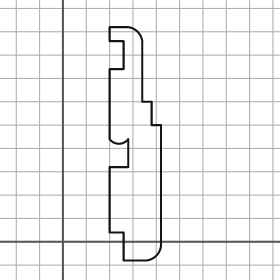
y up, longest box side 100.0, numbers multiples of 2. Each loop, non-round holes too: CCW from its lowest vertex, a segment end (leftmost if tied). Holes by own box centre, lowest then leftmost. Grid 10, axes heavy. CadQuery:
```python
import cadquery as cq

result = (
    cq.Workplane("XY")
    .moveTo(26.0, -8.0)
    .lineTo(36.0, -8.0)
    .threePointArc((40.0, -6.0), (42.0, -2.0))
    .lineTo(42.0, 50.0)
    .lineTo(38.0, 50.0)
    .lineTo(38.0, 60.0)
    .lineTo(34.0, 60.0)
    .lineTo(34.0, 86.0)
    .threePointArc((32.0, 90.0), (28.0, 92.0))
    .lineTo(20.0, 92.0)
    .lineTo(20.0, 86.0)
    .lineTo(26.0, 86.0)
    .lineTo(26.0, 74.0)
    .lineTo(20.0, 74.0)
    .lineTo(20.0, 44.0)
    .threePointArc((24.0, 42.0), (28.0, 44.0))
    .lineTo(28.0, 32.0)
    .lineTo(20.0, 32.0)
    .lineTo(20.0, 4.0)
    .lineTo(26.0, 4.0)
    .close()
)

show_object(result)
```